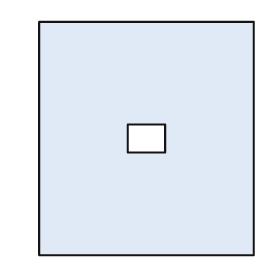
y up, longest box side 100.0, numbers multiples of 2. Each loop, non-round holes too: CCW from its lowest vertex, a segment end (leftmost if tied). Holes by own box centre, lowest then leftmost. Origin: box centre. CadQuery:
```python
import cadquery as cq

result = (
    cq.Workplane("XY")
    .moveTo(-46.0, -50.0)
    .lineTo(46.0, -50.0)
    .lineTo(46.0, 50.0)
    .lineTo(-46.0, 50.0)
    .close()
    .moveTo(-8.0, -6.0)
    .lineTo(8.0, -6.0)
    .lineTo(8.0, 6.0)
    .lineTo(-8.0, 6.0)
    .close()
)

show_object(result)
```